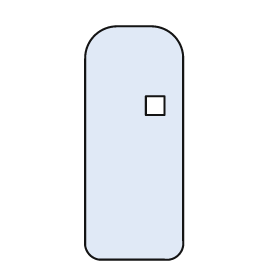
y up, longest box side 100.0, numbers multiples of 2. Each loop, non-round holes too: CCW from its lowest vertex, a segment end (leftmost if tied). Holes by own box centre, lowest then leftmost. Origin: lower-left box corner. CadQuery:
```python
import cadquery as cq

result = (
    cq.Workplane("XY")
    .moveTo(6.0, 0.0)
    .lineTo(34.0, 0.0)
    .threePointArc((40.0, 2.0), (42.0, 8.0))
    .lineTo(42.0, 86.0)
    .threePointArc((38.0, 96.0), (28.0, 100.0))
    .lineTo(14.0, 100.0)
    .threePointArc((4.0, 96.0), (0.0, 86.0))
    .lineTo(0.0, 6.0)
    .threePointArc((2.0, 2.0), (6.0, 0.0))
    .close()
    .moveTo(26.0, 62.0)
    .lineTo(34.0, 62.0)
    .lineTo(34.0, 70.0)
    .lineTo(26.0, 70.0)
    .close()
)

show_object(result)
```